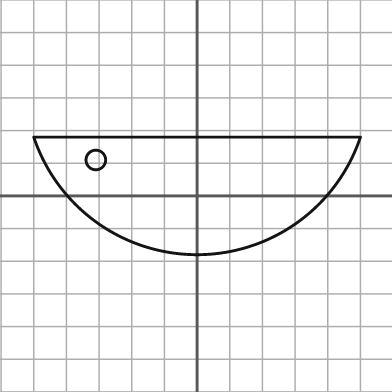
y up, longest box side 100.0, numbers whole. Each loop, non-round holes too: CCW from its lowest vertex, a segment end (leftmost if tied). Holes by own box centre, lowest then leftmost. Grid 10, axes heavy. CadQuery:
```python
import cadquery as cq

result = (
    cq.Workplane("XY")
    .moveTo(-50.0, 18.0)
    .threePointArc((0.0, -18.0), (50.0, 18.0))
    .close()
    .moveTo(-31.0, 11.0)
    .circle(3.0)
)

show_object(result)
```